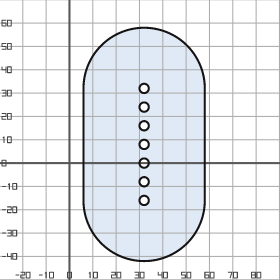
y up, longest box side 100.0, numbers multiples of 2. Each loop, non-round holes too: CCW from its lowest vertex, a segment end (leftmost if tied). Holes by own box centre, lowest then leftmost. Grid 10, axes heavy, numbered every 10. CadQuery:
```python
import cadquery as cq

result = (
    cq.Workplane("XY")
    .moveTo(6.0, -16.0)
    .threePointArc((32.0, -42.0), (58.0, -16.0))
    .lineTo(58.0, 32.0)
    .threePointArc((32.0, 58.0), (6.0, 32.0))
    .close()
    .moveTo(32.0, -16.0)
    .circle(2.0)
    .moveTo(32.0, -8.0)
    .circle(2.0)
    .moveTo(32.0, 0.0)
    .circle(2.0)
    .moveTo(32.0, 8.0)
    .circle(2.0)
    .moveTo(32.0, 16.0)
    .circle(2.0)
    .moveTo(32.0, 24.0)
    .circle(2.0)
    .moveTo(32.0, 32.0)
    .circle(2.0)
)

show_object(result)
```